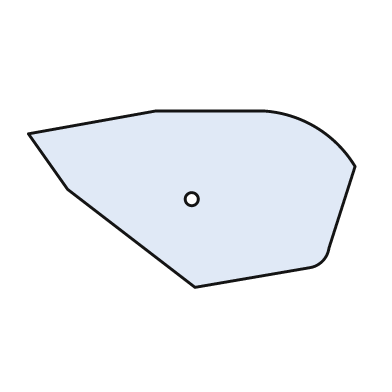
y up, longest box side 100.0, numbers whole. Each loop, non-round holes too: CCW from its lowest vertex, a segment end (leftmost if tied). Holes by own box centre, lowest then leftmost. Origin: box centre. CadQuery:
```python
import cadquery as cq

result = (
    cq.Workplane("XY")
    .moveTo(1.0, -27.0)
    .lineTo(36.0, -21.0)
    .threePointArc((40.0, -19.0), (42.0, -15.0))
    .lineTo(50.0, 10.0)
    .threePointArc((38.0, 22.0), (22.0, 27.0))
    .lineTo(-11.0, 27.0)
    .lineTo(-50.0, 20.0)
    .lineTo(-38.0, 3.0)
    .close()
    .moveTo(0.0, 0.0)
    .circle(2.0)
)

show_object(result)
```